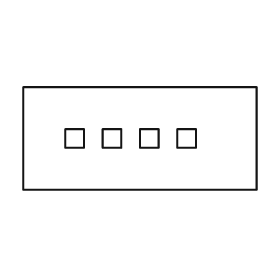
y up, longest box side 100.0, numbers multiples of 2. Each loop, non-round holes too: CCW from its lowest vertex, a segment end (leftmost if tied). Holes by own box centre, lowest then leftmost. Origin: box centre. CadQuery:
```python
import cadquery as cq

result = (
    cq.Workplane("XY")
    .moveTo(-50.0, -22.0)
    .lineTo(50.0, -22.0)
    .lineTo(50.0, 22.0)
    .lineTo(-50.0, 22.0)
    .close()
    .moveTo(-32.0, -4.0)
    .lineTo(-24.0, -4.0)
    .lineTo(-24.0, 4.0)
    .lineTo(-32.0, 4.0)
    .close()
    .moveTo(-16.0, -4.0)
    .lineTo(-8.0, -4.0)
    .lineTo(-8.0, 4.0)
    .lineTo(-16.0, 4.0)
    .close()
    .moveTo(0.0, -4.0)
    .lineTo(8.0, -4.0)
    .lineTo(8.0, 4.0)
    .lineTo(0.0, 4.0)
    .close()
    .moveTo(16.0, -4.0)
    .lineTo(24.0, -4.0)
    .lineTo(24.0, 4.0)
    .lineTo(16.0, 4.0)
    .close()
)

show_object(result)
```